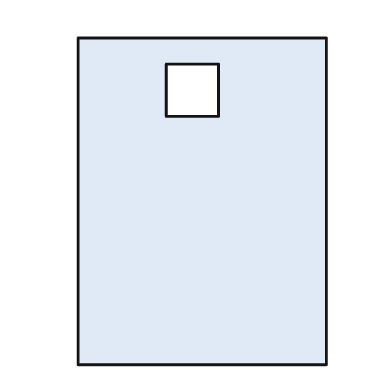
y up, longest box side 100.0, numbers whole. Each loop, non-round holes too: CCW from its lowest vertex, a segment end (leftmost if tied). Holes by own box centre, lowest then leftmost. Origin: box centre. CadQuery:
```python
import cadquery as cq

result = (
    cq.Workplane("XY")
    .moveTo(-38.0, -50.0)
    .lineTo(38.0, -50.0)
    .lineTo(38.0, 50.0)
    .lineTo(-38.0, 50.0)
    .close()
    .moveTo(-11.0, 26.0)
    .lineTo(5.0, 26.0)
    .lineTo(5.0, 42.0)
    .lineTo(-11.0, 42.0)
    .close()
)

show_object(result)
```